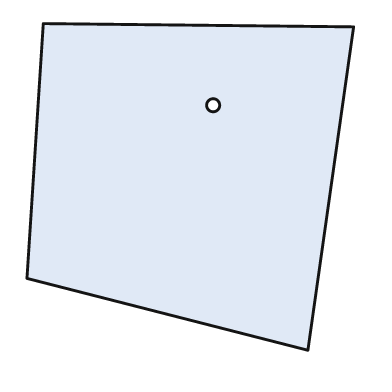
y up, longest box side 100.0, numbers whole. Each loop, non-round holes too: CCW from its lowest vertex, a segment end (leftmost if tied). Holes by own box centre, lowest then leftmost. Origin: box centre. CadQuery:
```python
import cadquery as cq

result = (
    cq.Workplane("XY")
    .moveTo(36.0, -50.0)
    .lineTo(50.0, 49.0)
    .lineTo(-45.0, 50.0)
    .lineTo(-50.0, -28.0)
    .close()
    .moveTo(7.0, 25.0)
    .circle(2.0)
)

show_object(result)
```